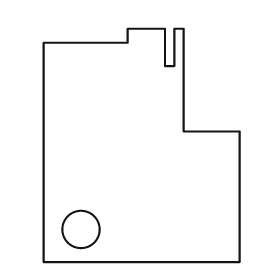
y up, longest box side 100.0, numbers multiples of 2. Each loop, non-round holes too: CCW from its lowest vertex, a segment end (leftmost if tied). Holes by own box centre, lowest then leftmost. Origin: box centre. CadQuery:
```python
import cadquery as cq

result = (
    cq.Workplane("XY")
    .moveTo(-42.0, -50.0)
    .lineTo(42.0, -50.0)
    .lineTo(42.0, 6.0)
    .lineTo(18.0, 6.0)
    .lineTo(18.0, 50.0)
    .lineTo(14.0, 50.0)
    .lineTo(14.0, 34.0)
    .lineTo(10.0, 34.0)
    .lineTo(10.0, 50.0)
    .lineTo(-6.0, 50.0)
    .lineTo(-6.0, 44.0)
    .lineTo(-42.0, 44.0)
    .close()
    .moveTo(-26.0, -36.0)
    .circle(8.0)
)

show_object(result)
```